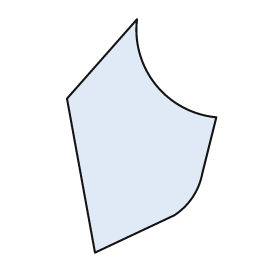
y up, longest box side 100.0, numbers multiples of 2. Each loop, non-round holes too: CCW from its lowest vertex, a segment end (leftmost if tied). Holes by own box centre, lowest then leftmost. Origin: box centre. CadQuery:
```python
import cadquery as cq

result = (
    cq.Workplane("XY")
    .moveTo(-20.0, -50.0)
    .lineTo(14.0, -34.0)
    .threePointArc((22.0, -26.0), (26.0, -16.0))
    .lineTo(32.0, 8.0)
    .threePointArc((6.0, 22.0), (-2.0, 50.0))
    .lineTo(-32.0, 16.0)
    .close()
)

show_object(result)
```